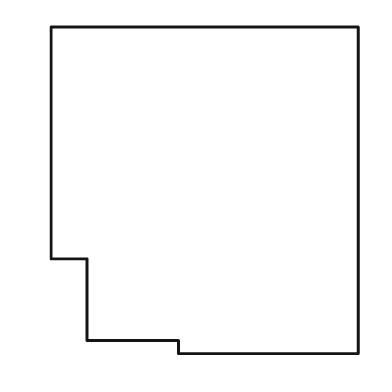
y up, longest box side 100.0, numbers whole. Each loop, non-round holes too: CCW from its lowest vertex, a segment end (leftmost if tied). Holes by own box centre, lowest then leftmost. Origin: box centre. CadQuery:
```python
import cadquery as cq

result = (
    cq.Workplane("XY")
    .moveTo(-8.0, -50.0)
    .lineTo(47.0, -50.0)
    .lineTo(47.0, 50.0)
    .lineTo(-47.0, 50.0)
    .lineTo(-47.0, -21.0)
    .lineTo(-36.0, -21.0)
    .lineTo(-36.0, -46.0)
    .lineTo(-8.0, -46.0)
    .close()
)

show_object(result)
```